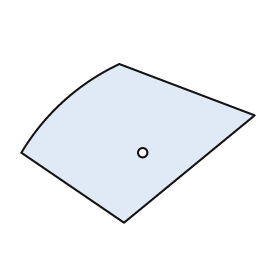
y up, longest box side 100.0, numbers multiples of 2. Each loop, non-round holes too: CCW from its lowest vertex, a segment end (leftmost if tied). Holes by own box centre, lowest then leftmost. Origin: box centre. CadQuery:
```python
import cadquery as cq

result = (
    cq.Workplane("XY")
    .moveTo(-6.0, -34.0)
    .lineTo(50.0, 12.0)
    .lineTo(-8.0, 34.0)
    .threePointArc((-32.0, 18.0), (-50.0, -4.0))
    .close()
    .moveTo(2.0, -4.0)
    .circle(2.0)
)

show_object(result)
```